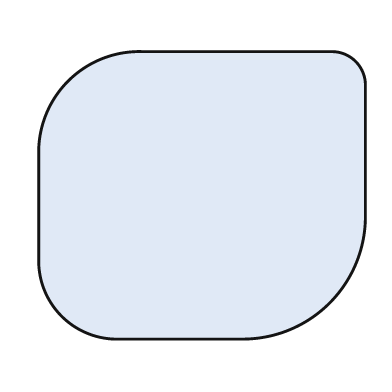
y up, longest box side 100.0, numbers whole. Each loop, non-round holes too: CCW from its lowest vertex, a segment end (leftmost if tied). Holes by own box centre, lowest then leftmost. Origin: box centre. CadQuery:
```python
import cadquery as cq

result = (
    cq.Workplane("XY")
    .moveTo(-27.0, -44.0)
    .lineTo(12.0, -44.0)
    .threePointArc((39.0, -33.0), (50.0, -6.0))
    .lineTo(50.0, 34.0)
    .threePointArc((47.0, 41.0), (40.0, 44.0))
    .lineTo(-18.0, 44.0)
    .threePointArc((-41.0, 35.0), (-50.0, 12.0))
    .lineTo(-50.0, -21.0)
    .threePointArc((-43.0, -37.0), (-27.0, -44.0))
    .close()
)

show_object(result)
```